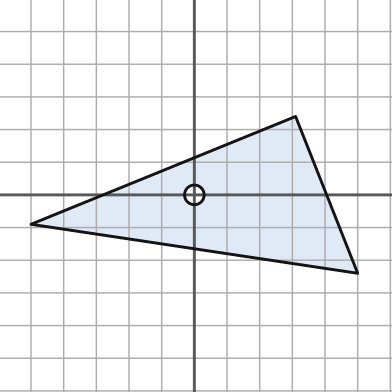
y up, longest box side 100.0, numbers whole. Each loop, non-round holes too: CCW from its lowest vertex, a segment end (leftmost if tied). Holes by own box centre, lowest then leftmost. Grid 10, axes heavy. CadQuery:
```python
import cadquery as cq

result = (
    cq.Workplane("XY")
    .moveTo(50.0, -24.0)
    .lineTo(31.0, 24.0)
    .lineTo(-50.0, -9.0)
    .close()
    .moveTo(0.0, 0.0)
    .circle(3.0)
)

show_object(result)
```